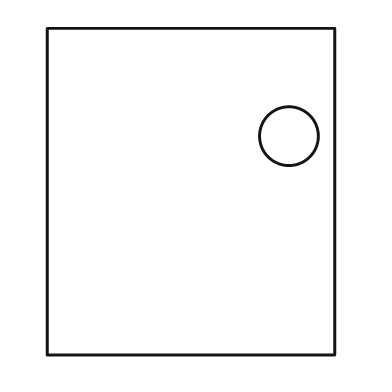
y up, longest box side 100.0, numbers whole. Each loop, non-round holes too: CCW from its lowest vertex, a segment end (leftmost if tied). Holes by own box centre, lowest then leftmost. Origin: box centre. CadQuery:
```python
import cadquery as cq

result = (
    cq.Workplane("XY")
    .moveTo(-44.0, -50.0)
    .lineTo(44.0, -50.0)
    .lineTo(44.0, 50.0)
    .lineTo(-44.0, 50.0)
    .close()
    .moveTo(30.0, 17.0)
    .circle(9.0)
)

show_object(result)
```